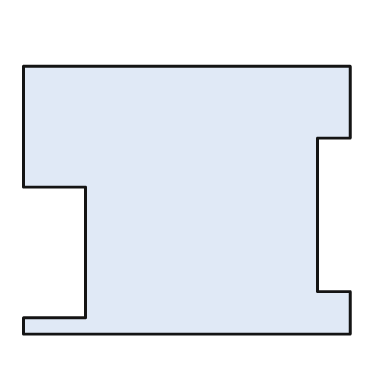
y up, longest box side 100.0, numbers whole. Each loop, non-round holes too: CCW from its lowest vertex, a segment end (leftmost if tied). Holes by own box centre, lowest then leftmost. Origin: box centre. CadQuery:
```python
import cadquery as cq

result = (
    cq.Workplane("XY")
    .moveTo(-50.0, -41.0)
    .lineTo(50.0, -41.0)
    .lineTo(50.0, -28.0)
    .lineTo(40.0, -28.0)
    .lineTo(40.0, 19.0)
    .lineTo(50.0, 19.0)
    .lineTo(50.0, 41.0)
    .lineTo(-50.0, 41.0)
    .lineTo(-50.0, 4.0)
    .lineTo(-31.0, 4.0)
    .lineTo(-31.0, -36.0)
    .lineTo(-50.0, -36.0)
    .close()
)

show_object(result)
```